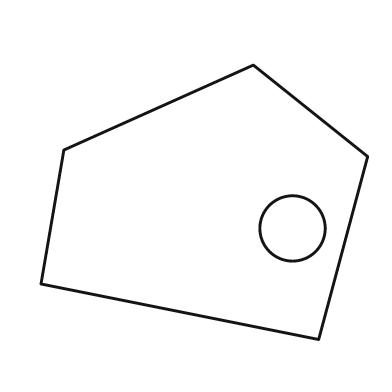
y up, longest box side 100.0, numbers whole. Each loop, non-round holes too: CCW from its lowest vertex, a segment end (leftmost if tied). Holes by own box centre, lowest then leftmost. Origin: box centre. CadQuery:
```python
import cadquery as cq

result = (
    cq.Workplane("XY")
    .moveTo(35.0, -42.0)
    .lineTo(50.0, 14.0)
    .lineTo(15.0, 42.0)
    .lineTo(-43.0, 16.0)
    .lineTo(-50.0, -25.0)
    .close()
    .moveTo(27.0, -8.0)
    .circle(10.0)
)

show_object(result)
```